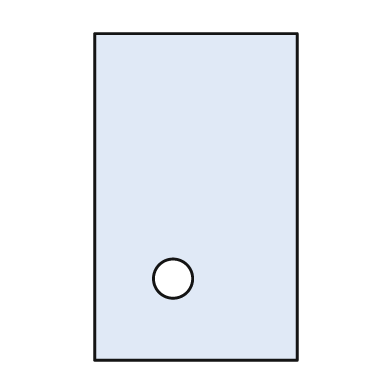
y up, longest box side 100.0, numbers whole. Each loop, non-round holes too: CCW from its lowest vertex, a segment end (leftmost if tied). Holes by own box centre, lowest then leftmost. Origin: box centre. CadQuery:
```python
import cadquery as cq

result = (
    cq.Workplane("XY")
    .moveTo(-31.0, -50.0)
    .lineTo(31.0, -50.0)
    .lineTo(31.0, 50.0)
    .lineTo(-31.0, 50.0)
    .close()
    .moveTo(-7.0, -25.0)
    .circle(6.0)
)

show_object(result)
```